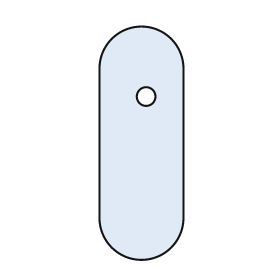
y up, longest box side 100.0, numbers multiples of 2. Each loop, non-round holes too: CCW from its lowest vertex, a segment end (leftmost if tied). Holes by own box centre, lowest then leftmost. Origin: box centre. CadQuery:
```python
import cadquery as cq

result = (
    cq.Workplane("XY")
    .moveTo(-18.0, -32.0)
    .threePointArc((0.0, -50.0), (18.0, -32.0))
    .lineTo(18.0, 32.0)
    .threePointArc((0.0, 50.0), (-18.0, 32.0))
    .close()
    .moveTo(2.0, 20.0)
    .circle(4.0)
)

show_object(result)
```